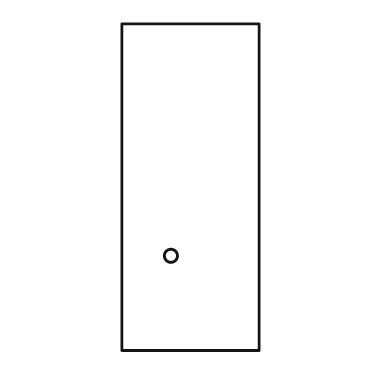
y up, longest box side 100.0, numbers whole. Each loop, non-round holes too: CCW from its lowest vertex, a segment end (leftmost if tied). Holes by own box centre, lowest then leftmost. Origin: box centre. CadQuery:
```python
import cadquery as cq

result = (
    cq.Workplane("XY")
    .moveTo(-21.0, -50.0)
    .lineTo(21.0, -50.0)
    .lineTo(21.0, 50.0)
    .lineTo(-21.0, 50.0)
    .close()
    .moveTo(-6.0, -21.0)
    .circle(2.0)
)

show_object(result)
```